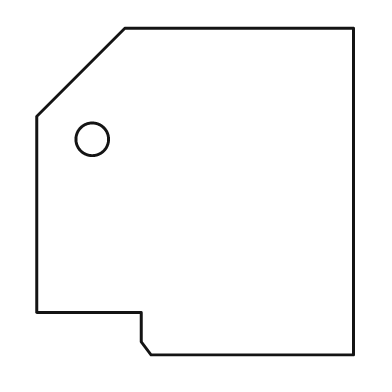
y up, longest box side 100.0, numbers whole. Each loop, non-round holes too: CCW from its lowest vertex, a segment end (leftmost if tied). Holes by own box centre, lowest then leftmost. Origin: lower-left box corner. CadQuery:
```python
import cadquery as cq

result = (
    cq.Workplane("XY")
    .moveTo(35.0, 0.0)
    .lineTo(97.0, 0.0)
    .lineTo(97.0, 100.0)
    .lineTo(27.0, 100.0)
    .lineTo(0.0, 73.0)
    .lineTo(0.0, 13.0)
    .lineTo(32.0, 13.0)
    .lineTo(32.0, 4.0)
    .close()
    .moveTo(17.0, 66.0)
    .circle(5.0)
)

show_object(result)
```